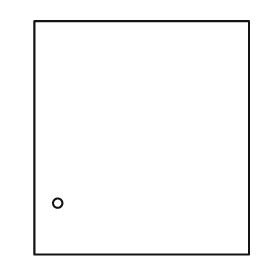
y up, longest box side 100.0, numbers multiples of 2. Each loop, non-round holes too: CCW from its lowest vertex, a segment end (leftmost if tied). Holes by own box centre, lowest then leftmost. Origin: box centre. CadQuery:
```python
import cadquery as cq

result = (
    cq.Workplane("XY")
    .moveTo(-46.0, -50.0)
    .lineTo(46.0, -50.0)
    .lineTo(46.0, 50.0)
    .lineTo(-46.0, 50.0)
    .close()
    .moveTo(-36.0, -28.0)
    .circle(2.0)
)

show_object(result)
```